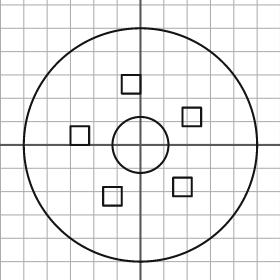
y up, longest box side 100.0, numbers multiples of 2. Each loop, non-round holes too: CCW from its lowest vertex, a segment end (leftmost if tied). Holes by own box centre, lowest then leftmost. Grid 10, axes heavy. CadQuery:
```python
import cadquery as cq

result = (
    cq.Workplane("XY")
    .moveTo(0.0, 0.0)
    .circle(50.0)
    .moveTo(-16.0, -26.0)
    .lineTo(-8.0, -26.0)
    .lineTo(-8.0, -18.0)
    .lineTo(-16.0, -18.0)
    .close()
    .moveTo(14.0, -22.0)
    .lineTo(22.0, -22.0)
    .lineTo(22.0, -14.0)
    .lineTo(14.0, -14.0)
    .close()
    .moveTo(0.0, 0.0)
    .circle(12.0)
    .moveTo(-30.0, 0.0)
    .lineTo(-22.0, 0.0)
    .lineTo(-22.0, 8.0)
    .lineTo(-30.0, 8.0)
    .close()
    .moveTo(18.0, 8.0)
    .lineTo(26.0, 8.0)
    .lineTo(26.0, 16.0)
    .lineTo(18.0, 16.0)
    .close()
    .moveTo(-8.0, 22.0)
    .lineTo(0.0, 22.0)
    .lineTo(0.0, 30.0)
    .lineTo(-8.0, 30.0)
    .close()
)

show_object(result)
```